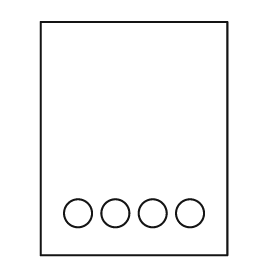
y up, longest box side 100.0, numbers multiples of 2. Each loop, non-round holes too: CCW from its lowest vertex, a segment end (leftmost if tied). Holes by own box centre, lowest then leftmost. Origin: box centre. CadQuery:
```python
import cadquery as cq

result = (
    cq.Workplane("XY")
    .moveTo(-40.0, -50.0)
    .lineTo(40.0, -50.0)
    .lineTo(40.0, 50.0)
    .lineTo(-40.0, 50.0)
    .close()
    .moveTo(-24.0, -32.0)
    .circle(6.0)
    .moveTo(-8.0, -32.0)
    .circle(6.0)
    .moveTo(8.0, -32.0)
    .circle(6.0)
    .moveTo(24.0, -32.0)
    .circle(6.0)
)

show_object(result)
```